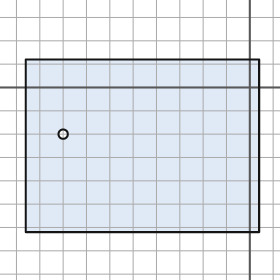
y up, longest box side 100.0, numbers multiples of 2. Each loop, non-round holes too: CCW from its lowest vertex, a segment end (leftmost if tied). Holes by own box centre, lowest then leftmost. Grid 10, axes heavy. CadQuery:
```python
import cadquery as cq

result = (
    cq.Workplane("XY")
    .moveTo(-96.0, -62.0)
    .lineTo(4.0, -62.0)
    .lineTo(4.0, 12.0)
    .lineTo(-96.0, 12.0)
    .close()
    .moveTo(-80.0, -20.0)
    .circle(2.0)
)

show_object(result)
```